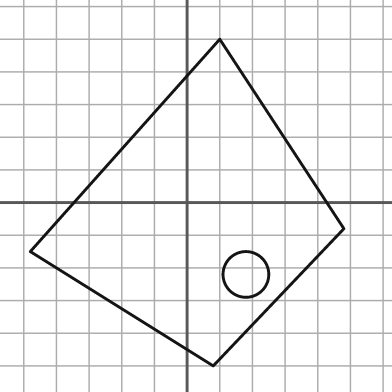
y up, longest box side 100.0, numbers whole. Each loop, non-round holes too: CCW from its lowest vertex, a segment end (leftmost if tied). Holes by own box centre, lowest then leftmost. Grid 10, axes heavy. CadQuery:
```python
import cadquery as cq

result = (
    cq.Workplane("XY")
    .moveTo(8.0, -50.0)
    .lineTo(48.0, -8.0)
    .lineTo(10.0, 50.0)
    .lineTo(-48.0, -15.0)
    .close()
    .moveTo(18.0, -22.0)
    .circle(7.0)
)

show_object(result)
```